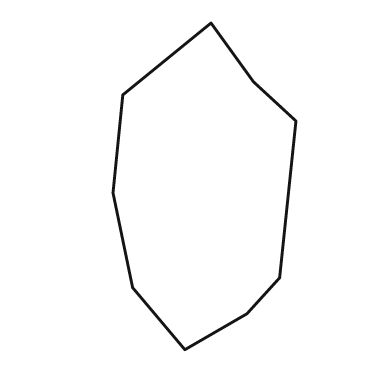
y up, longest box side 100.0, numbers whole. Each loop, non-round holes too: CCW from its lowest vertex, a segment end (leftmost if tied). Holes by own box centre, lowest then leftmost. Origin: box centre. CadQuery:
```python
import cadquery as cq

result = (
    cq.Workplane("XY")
    .moveTo(-6.0, -50.0)
    .lineTo(13.0, -39.0)
    .lineTo(23.0, -28.0)
    .lineTo(28.0, 20.0)
    .lineTo(15.0, 32.0)
    .lineTo(2.0, 50.0)
    .lineTo(-25.0, 28.0)
    .lineTo(-28.0, -2.0)
    .lineTo(-22.0, -31.0)
    .close()
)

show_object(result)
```